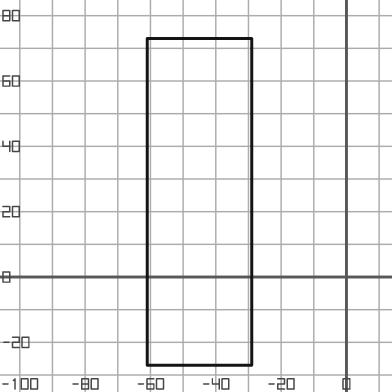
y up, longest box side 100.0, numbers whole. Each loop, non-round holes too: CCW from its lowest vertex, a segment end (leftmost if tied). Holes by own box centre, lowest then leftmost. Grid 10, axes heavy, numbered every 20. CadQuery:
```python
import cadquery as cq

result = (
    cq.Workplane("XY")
    .moveTo(-61.0, -27.0)
    .lineTo(-29.0, -27.0)
    .lineTo(-29.0, 73.0)
    .lineTo(-61.0, 73.0)
    .close()
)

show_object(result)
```